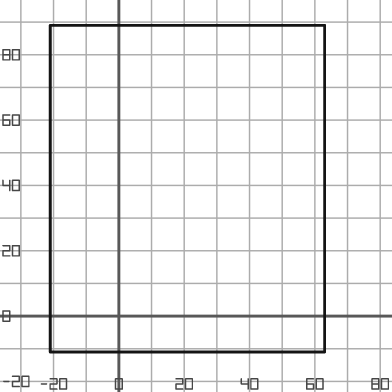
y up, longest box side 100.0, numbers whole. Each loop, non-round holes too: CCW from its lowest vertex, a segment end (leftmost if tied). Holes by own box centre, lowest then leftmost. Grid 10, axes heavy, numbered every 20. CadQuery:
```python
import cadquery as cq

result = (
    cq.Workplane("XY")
    .moveTo(-21.0, -11.0)
    .lineTo(63.0, -11.0)
    .lineTo(63.0, 89.0)
    .lineTo(-21.0, 89.0)
    .close()
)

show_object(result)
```